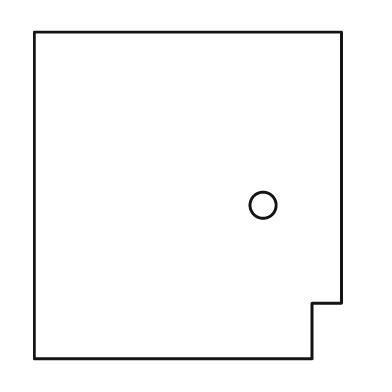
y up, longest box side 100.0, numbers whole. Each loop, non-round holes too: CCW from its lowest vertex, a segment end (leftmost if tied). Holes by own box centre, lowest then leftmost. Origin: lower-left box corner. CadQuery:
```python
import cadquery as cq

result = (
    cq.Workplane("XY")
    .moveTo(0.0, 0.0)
    .lineTo(85.0, 0.0)
    .lineTo(85.0, 17.0)
    .lineTo(94.0, 17.0)
    .lineTo(94.0, 100.0)
    .lineTo(0.0, 100.0)
    .close()
    .moveTo(70.0, 47.0)
    .circle(4.0)
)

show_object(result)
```